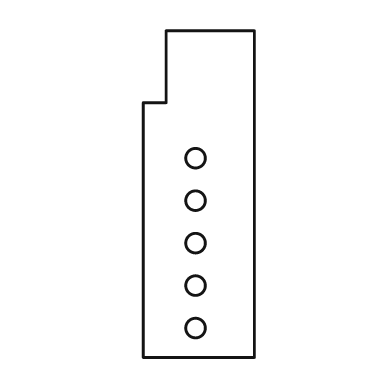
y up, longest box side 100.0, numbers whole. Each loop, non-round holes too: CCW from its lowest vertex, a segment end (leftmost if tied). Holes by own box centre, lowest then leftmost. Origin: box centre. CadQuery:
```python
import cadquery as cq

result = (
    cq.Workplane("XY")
    .moveTo(-17.0, -50.0)
    .lineTo(17.0, -50.0)
    .lineTo(17.0, 50.0)
    .lineTo(-10.0, 50.0)
    .lineTo(-10.0, 28.0)
    .lineTo(-17.0, 28.0)
    .close()
    .moveTo(-1.0, -41.0)
    .circle(3.0)
    .moveTo(-1.0, -28.0)
    .circle(3.0)
    .moveTo(-1.0, -15.0)
    .circle(3.0)
    .moveTo(-1.0, -2.0)
    .circle(3.0)
    .moveTo(-1.0, 11.0)
    .circle(3.0)
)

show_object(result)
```